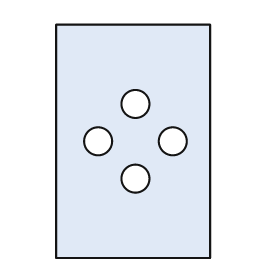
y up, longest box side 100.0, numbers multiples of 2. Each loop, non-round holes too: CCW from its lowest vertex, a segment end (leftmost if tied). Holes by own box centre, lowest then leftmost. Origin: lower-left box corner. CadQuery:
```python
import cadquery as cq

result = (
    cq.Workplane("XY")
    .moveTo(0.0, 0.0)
    .lineTo(66.0, 0.0)
    .lineTo(66.0, 100.0)
    .lineTo(0.0, 100.0)
    .close()
    .moveTo(34.0, 34.0)
    .circle(6.0)
    .moveTo(18.0, 50.0)
    .circle(6.0)
    .moveTo(50.0, 50.0)
    .circle(6.0)
    .moveTo(34.0, 66.0)
    .circle(6.0)
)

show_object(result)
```